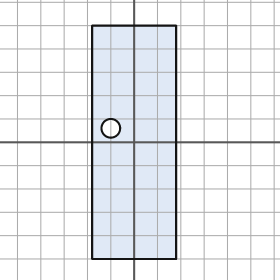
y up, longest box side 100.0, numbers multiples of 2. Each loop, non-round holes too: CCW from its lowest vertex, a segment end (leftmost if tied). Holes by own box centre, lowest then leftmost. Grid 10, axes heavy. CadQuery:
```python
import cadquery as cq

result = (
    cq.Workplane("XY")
    .moveTo(-18.0, -50.0)
    .lineTo(18.0, -50.0)
    .lineTo(18.0, 50.0)
    .lineTo(-18.0, 50.0)
    .close()
    .moveTo(-10.0, 6.0)
    .circle(4.0)
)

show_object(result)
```